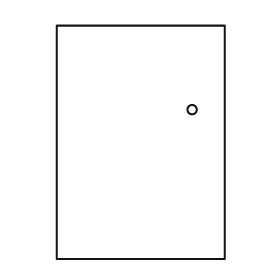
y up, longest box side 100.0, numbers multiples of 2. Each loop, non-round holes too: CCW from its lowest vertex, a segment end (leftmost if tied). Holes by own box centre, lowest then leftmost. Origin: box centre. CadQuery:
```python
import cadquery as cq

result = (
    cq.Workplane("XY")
    .moveTo(-36.0, -50.0)
    .lineTo(36.0, -50.0)
    .lineTo(36.0, 50.0)
    .lineTo(-36.0, 50.0)
    .close()
    .moveTo(22.0, 14.0)
    .circle(2.0)
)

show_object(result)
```